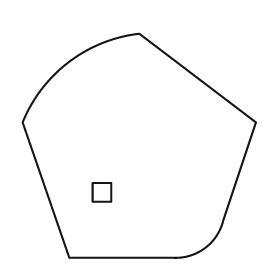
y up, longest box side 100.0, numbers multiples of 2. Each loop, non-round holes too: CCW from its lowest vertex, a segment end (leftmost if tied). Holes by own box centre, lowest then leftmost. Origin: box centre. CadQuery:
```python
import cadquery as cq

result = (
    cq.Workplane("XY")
    .moveTo(-30.0, -48.0)
    .lineTo(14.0, -48.0)
    .threePointArc((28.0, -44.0), (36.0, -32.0))
    .lineTo(50.0, 10.0)
    .lineTo(0.0, 48.0)
    .threePointArc((-30.0, 36.0), (-50.0, 10.0))
    .close()
    .moveTo(-20.0, -24.0)
    .lineTo(-12.0, -24.0)
    .lineTo(-12.0, -16.0)
    .lineTo(-20.0, -16.0)
    .close()
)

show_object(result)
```